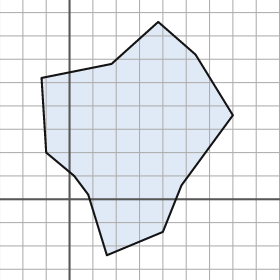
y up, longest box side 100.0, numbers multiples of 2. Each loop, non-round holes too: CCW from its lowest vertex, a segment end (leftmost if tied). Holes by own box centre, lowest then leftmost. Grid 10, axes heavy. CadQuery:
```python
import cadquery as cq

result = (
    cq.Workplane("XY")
    .moveTo(16.0, -24.0)
    .lineTo(40.0, -14.0)
    .lineTo(48.0, 6.0)
    .lineTo(70.0, 36.0)
    .lineTo(54.0, 62.0)
    .lineTo(38.0, 76.0)
    .lineTo(18.0, 58.0)
    .lineTo(-12.0, 52.0)
    .lineTo(-10.0, 20.0)
    .lineTo(2.0, 10.0)
    .lineTo(8.0, 2.0)
    .close()
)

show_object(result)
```